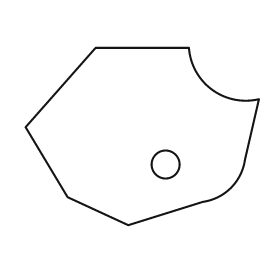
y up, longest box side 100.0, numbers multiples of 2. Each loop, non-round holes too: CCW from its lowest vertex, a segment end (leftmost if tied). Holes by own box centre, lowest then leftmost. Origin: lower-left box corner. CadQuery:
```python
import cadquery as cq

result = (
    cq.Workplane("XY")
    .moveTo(44.0, 0.0)
    .lineTo(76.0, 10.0)
    .threePointArc((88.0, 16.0), (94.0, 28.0))
    .lineTo(100.0, 54.0)
    .threePointArc((80.0, 58.0), (70.0, 76.0))
    .lineTo(30.0, 76.0)
    .lineTo(0.0, 42.0)
    .lineTo(18.0, 12.0)
    .close()
    .moveTo(60.0, 26.0)
    .circle(6.0)
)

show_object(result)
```